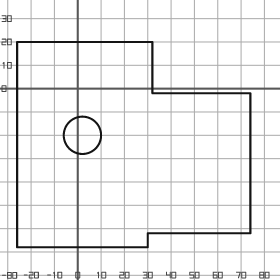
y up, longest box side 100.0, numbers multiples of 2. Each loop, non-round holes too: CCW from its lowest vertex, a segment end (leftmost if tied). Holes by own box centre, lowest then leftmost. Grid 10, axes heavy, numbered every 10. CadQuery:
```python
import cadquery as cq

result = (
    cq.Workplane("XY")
    .moveTo(-26.0, -68.0)
    .lineTo(30.0, -68.0)
    .lineTo(30.0, -62.0)
    .lineTo(74.0, -62.0)
    .lineTo(74.0, -2.0)
    .lineTo(32.0, -2.0)
    .lineTo(32.0, 20.0)
    .lineTo(-26.0, 20.0)
    .close()
    .moveTo(2.0, -20.0)
    .circle(8.0)
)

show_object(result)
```